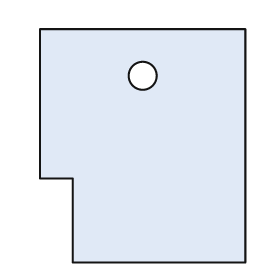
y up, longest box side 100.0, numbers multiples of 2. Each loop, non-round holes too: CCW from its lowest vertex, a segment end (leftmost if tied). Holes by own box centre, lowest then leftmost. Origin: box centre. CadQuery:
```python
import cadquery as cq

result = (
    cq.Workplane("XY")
    .moveTo(-30.0, -50.0)
    .lineTo(44.0, -50.0)
    .lineTo(44.0, 50.0)
    .lineTo(-44.0, 50.0)
    .lineTo(-44.0, -14.0)
    .lineTo(-30.0, -14.0)
    .close()
    .moveTo(0.0, 30.0)
    .circle(6.0)
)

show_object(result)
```